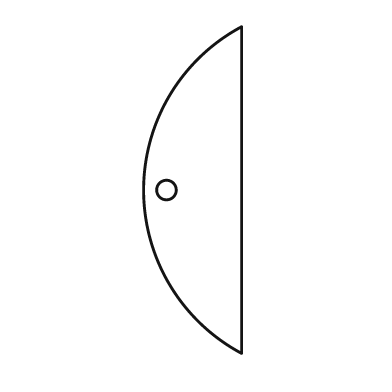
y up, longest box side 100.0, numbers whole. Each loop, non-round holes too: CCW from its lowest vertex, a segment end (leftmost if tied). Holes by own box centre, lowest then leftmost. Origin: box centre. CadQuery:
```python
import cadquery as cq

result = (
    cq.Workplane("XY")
    .moveTo(15.0, -50.0)
    .lineTo(15.0, 50.0)
    .threePointArc((-15.0, 0.0), (15.0, -50.0))
    .close()
    .moveTo(-8.0, 0.0)
    .circle(3.0)
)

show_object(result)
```